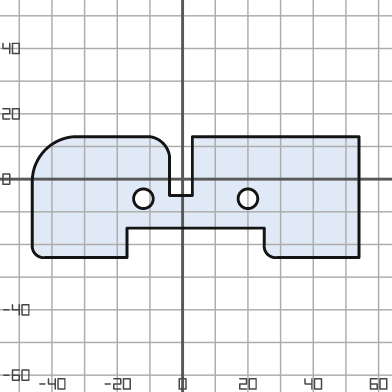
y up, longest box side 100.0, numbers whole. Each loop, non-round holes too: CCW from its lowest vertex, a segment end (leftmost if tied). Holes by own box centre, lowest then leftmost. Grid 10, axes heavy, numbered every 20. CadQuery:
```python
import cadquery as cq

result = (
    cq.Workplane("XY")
    .moveTo(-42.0, -24.0)
    .lineTo(-17.0, -24.0)
    .lineTo(-17.0, -15.0)
    .lineTo(25.0, -15.0)
    .lineTo(25.0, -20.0)
    .threePointArc((26.0, -23.0), (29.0, -24.0))
    .lineTo(54.0, -24.0)
    .lineTo(54.0, 13.0)
    .lineTo(3.0, 13.0)
    .lineTo(3.0, -5.0)
    .lineTo(-4.0, -5.0)
    .lineTo(-4.0, 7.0)
    .threePointArc((-6.0, 11.0), (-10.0, 13.0))
    .lineTo(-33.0, 13.0)
    .threePointArc((-42.0, 9.0), (-46.0, 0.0))
    .lineTo(-46.0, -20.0)
    .threePointArc((-45.0, -23.0), (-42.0, -24.0))
    .close()
    .moveTo(-12.0, -6.0)
    .circle(3.0)
    .moveTo(20.0, -6.0)
    .circle(3.0)
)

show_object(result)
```